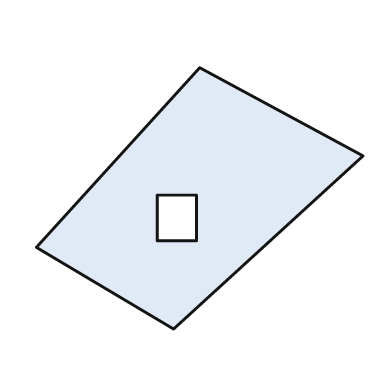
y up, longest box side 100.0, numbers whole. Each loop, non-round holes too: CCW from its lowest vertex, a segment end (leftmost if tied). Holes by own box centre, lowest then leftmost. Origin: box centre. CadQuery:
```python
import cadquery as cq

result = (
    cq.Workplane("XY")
    .moveTo(-8.0, -40.0)
    .lineTo(50.0, 13.0)
    .lineTo(0.0, 40.0)
    .lineTo(-50.0, -15.0)
    .close()
    .moveTo(-13.0, -13.0)
    .lineTo(-1.0, -13.0)
    .lineTo(-1.0, 1.0)
    .lineTo(-13.0, 1.0)
    .close()
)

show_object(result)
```